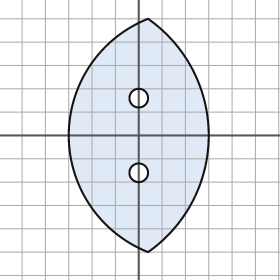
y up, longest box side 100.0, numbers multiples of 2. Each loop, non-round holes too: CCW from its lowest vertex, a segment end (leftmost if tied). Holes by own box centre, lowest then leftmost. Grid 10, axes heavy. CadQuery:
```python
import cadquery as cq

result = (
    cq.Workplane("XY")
    .moveTo(4.0, -50.0)
    .threePointArc((30.0, 0.0), (4.0, 50.0))
    .threePointArc((-30.0, 0.0), (4.0, -50.0))
    .close()
    .moveTo(0.0, -16.0)
    .circle(4.0)
    .moveTo(0.0, 16.0)
    .circle(4.0)
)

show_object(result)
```